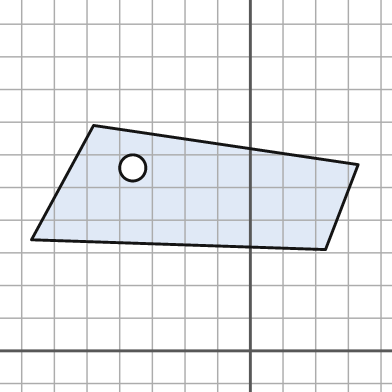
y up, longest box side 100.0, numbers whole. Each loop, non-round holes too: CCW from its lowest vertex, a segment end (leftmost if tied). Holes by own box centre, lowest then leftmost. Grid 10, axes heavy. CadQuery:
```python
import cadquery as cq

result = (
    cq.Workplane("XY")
    .moveTo(23.0, 31.0)
    .lineTo(33.0, 57.0)
    .lineTo(-48.0, 69.0)
    .lineTo(-67.0, 34.0)
    .close()
    .moveTo(-36.0, 56.0)
    .circle(4.0)
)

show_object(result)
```